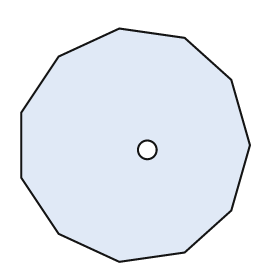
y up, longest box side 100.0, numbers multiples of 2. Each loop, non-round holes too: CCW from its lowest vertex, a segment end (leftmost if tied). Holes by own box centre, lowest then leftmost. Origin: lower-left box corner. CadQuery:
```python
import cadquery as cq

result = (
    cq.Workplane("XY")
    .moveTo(42.0, 0.0)
    .lineTo(70.0, 4.0)
    .lineTo(90.0, 22.0)
    .lineTo(98.0, 50.0)
    .lineTo(90.0, 78.0)
    .lineTo(70.0, 96.0)
    .lineTo(42.0, 100.0)
    .lineTo(16.0, 88.0)
    .lineTo(0.0, 64.0)
    .lineTo(0.0, 36.0)
    .lineTo(16.0, 12.0)
    .close()
    .moveTo(54.0, 48.0)
    .circle(4.0)
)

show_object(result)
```